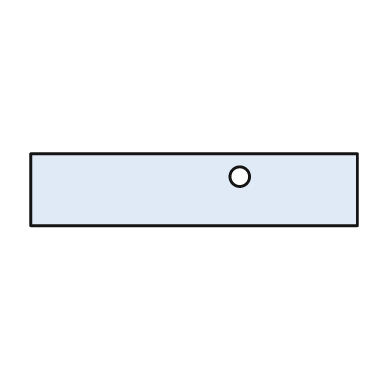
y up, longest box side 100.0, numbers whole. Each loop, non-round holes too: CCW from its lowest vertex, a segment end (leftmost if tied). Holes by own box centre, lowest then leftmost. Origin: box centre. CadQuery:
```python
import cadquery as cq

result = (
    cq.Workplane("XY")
    .moveTo(-50.0, -11.0)
    .lineTo(50.0, -11.0)
    .lineTo(50.0, 11.0)
    .lineTo(-50.0, 11.0)
    .close()
    .moveTo(14.0, 4.0)
    .circle(3.0)
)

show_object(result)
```